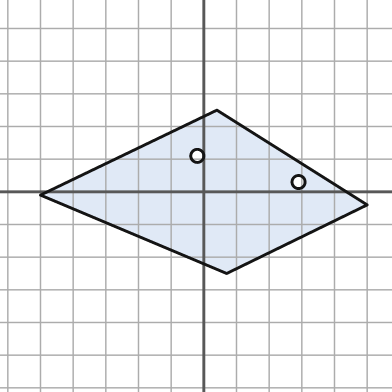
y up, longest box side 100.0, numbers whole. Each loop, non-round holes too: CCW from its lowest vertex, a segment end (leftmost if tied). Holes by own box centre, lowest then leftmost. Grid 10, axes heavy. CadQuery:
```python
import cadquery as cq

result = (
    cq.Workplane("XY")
    .moveTo(7.0, -25.0)
    .lineTo(50.0, -4.0)
    .lineTo(4.0, 25.0)
    .lineTo(-50.0, -1.0)
    .close()
    .moveTo(29.0, 3.0)
    .circle(2.0)
    .moveTo(-2.0, 11.0)
    .circle(2.0)
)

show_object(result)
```